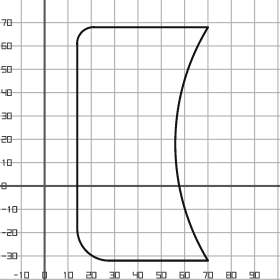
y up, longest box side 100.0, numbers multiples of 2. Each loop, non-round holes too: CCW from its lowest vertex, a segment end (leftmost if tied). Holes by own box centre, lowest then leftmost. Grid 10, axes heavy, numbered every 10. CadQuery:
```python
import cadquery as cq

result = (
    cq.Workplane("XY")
    .moveTo(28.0, -32.0)
    .lineTo(70.0, -32.0)
    .threePointArc((56.0, 18.0), (70.0, 68.0))
    .lineTo(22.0, 68.0)
    .threePointArc((16.0, 66.0), (14.0, 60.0))
    .lineTo(14.0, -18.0)
    .threePointArc((18.0, -28.0), (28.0, -32.0))
    .close()
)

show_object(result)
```